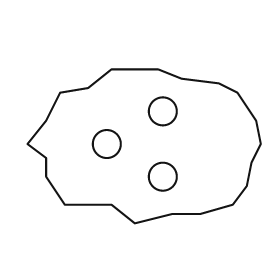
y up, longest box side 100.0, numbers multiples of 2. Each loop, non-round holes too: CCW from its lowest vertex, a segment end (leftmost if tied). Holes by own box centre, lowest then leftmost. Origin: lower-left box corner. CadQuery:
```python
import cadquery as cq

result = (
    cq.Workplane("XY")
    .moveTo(46.0, 0.0)
    .lineTo(62.0, 4.0)
    .lineTo(74.0, 4.0)
    .lineTo(88.0, 8.0)
    .lineTo(94.0, 16.0)
    .lineTo(96.0, 26.0)
    .lineTo(100.0, 34.0)
    .lineTo(98.0, 44.0)
    .lineTo(90.0, 56.0)
    .lineTo(82.0, 60.0)
    .lineTo(66.0, 62.0)
    .lineTo(56.0, 66.0)
    .lineTo(36.0, 66.0)
    .lineTo(26.0, 58.0)
    .lineTo(14.0, 56.0)
    .lineTo(8.0, 44.0)
    .lineTo(0.0, 34.0)
    .lineTo(8.0, 28.0)
    .lineTo(8.0, 20.0)
    .lineTo(16.0, 8.0)
    .lineTo(36.0, 8.0)
    .close()
    .moveTo(58.0, 20.0)
    .circle(6.0)
    .moveTo(34.0, 34.0)
    .circle(6.0)
    .moveTo(58.0, 48.0)
    .circle(6.0)
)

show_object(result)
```